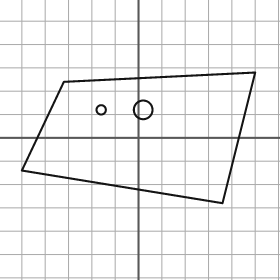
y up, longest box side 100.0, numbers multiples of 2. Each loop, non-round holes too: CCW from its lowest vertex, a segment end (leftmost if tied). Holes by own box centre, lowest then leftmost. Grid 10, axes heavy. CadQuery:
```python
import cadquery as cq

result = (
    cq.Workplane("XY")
    .moveTo(36.0, -28.0)
    .lineTo(50.0, 28.0)
    .lineTo(-32.0, 24.0)
    .lineTo(-50.0, -14.0)
    .close()
    .moveTo(-16.0, 12.0)
    .circle(2.0)
    .moveTo(2.0, 12.0)
    .circle(4.0)
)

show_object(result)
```